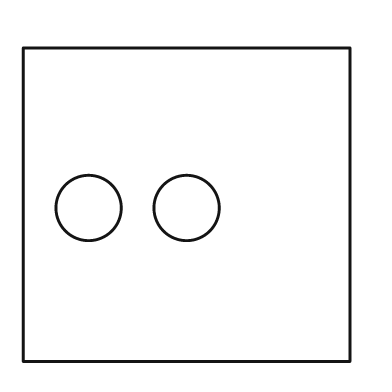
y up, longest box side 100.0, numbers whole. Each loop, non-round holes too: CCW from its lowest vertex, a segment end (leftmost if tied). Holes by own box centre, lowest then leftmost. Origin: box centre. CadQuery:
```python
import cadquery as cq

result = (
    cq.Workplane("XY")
    .moveTo(-50.0, -48.0)
    .lineTo(50.0, -48.0)
    .lineTo(50.0, 48.0)
    .lineTo(-50.0, 48.0)
    .close()
    .moveTo(-30.0, -1.0)
    .circle(10.0)
    .moveTo(0.0, -1.0)
    .circle(10.0)
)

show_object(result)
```